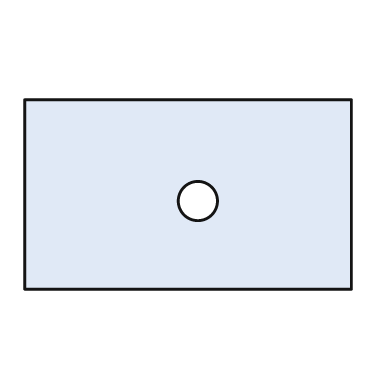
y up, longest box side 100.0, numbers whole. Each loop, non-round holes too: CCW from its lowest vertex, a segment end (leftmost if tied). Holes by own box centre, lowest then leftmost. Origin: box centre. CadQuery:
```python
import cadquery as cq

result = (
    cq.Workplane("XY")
    .moveTo(-50.0, -29.0)
    .lineTo(50.0, -29.0)
    .lineTo(50.0, 29.0)
    .lineTo(-50.0, 29.0)
    .close()
    .moveTo(3.0, -2.0)
    .circle(6.0)
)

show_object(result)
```